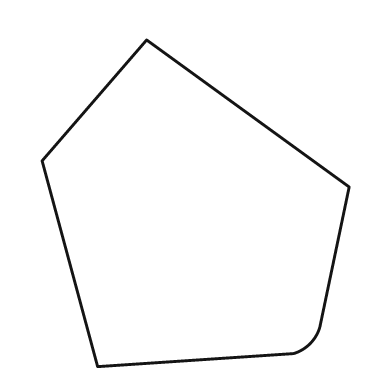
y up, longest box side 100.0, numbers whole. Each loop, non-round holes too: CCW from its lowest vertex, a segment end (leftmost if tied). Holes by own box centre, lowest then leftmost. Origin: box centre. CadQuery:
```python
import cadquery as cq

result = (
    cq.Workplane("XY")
    .moveTo(-30.0, -50.0)
    .lineTo(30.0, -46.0)
    .threePointArc((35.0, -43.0), (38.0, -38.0))
    .lineTo(47.0, 5.0)
    .lineTo(-15.0, 50.0)
    .lineTo(-47.0, 13.0)
    .close()
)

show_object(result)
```